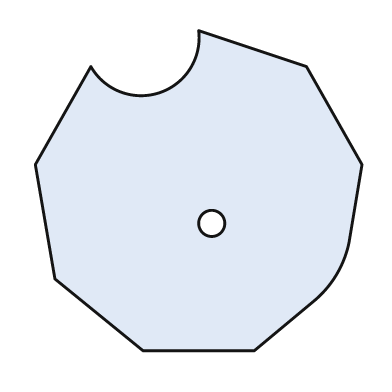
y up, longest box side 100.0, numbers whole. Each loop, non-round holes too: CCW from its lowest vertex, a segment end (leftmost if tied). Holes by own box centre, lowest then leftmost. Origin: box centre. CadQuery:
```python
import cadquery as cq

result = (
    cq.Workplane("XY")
    .moveTo(-17.0, -49.0)
    .lineTo(17.0, -49.0)
    .lineTo(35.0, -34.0)
    .threePointArc((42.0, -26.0), (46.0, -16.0))
    .lineTo(50.0, 8.0)
    .lineTo(33.0, 38.0)
    .lineTo(0.0, 49.0)
    .threePointArc((-12.0, 30.0), (-33.0, 38.0))
    .lineTo(-50.0, 8.0)
    .lineTo(-44.0, -27.0)
    .close()
    .moveTo(4.0, -10.0)
    .circle(4.0)
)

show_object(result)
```